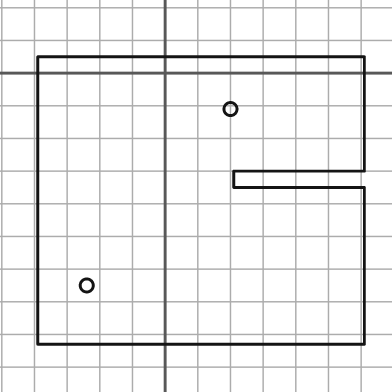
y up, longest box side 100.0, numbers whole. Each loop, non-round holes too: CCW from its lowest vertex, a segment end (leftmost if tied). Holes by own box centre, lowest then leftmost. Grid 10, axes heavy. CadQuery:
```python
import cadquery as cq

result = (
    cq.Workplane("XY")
    .moveTo(-39.0, -83.0)
    .lineTo(61.0, -83.0)
    .lineTo(61.0, -35.0)
    .lineTo(21.0, -35.0)
    .lineTo(21.0, -30.0)
    .lineTo(61.0, -30.0)
    .lineTo(61.0, 5.0)
    .lineTo(-39.0, 5.0)
    .close()
    .moveTo(-24.0, -65.0)
    .circle(2.0)
    .moveTo(20.0, -11.0)
    .circle(2.0)
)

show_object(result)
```